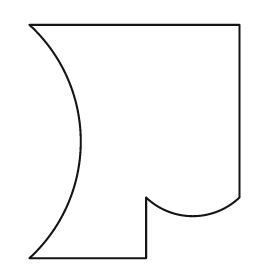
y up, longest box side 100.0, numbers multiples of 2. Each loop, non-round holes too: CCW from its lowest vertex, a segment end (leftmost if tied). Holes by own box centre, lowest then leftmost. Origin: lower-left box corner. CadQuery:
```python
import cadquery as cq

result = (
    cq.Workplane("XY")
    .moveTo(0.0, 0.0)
    .lineTo(50.0, 0.0)
    .lineTo(50.0, 26.0)
    .threePointArc((70.0, 18.0), (90.0, 26.0))
    .lineTo(90.0, 100.0)
    .lineTo(0.0, 100.0)
    .threePointArc((22.0, 50.0), (0.0, 0.0))
    .close()
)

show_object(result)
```